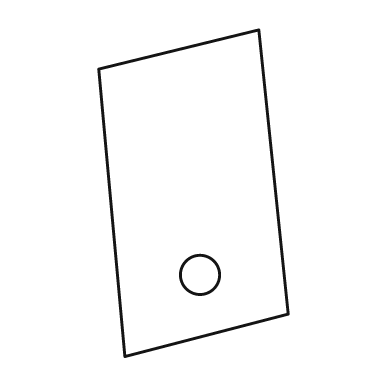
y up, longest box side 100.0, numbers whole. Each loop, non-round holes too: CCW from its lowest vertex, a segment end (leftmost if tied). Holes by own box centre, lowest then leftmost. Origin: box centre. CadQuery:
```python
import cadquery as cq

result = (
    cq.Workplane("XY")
    .moveTo(-21.0, -50.0)
    .lineTo(29.0, -37.0)
    .lineTo(20.0, 50.0)
    .lineTo(-29.0, 38.0)
    .close()
    .moveTo(2.0, -25.0)
    .circle(6.0)
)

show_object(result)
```